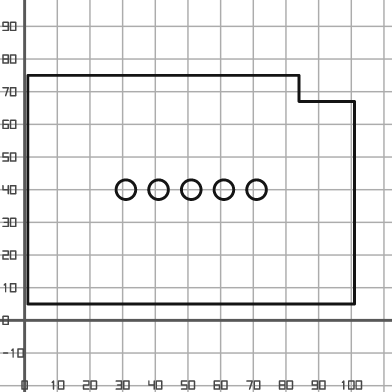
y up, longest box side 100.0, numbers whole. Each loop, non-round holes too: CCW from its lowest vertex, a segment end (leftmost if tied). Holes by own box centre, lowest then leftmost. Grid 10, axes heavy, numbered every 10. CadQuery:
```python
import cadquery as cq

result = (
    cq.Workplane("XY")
    .moveTo(1.0, 5.0)
    .lineTo(101.0, 5.0)
    .lineTo(101.0, 67.0)
    .lineTo(84.0, 67.0)
    .lineTo(84.0, 75.0)
    .lineTo(1.0, 75.0)
    .close()
    .moveTo(31.0, 40.0)
    .circle(3.0)
    .moveTo(41.0, 40.0)
    .circle(3.0)
    .moveTo(51.0, 40.0)
    .circle(3.0)
    .moveTo(61.0, 40.0)
    .circle(3.0)
    .moveTo(71.0, 40.0)
    .circle(3.0)
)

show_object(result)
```